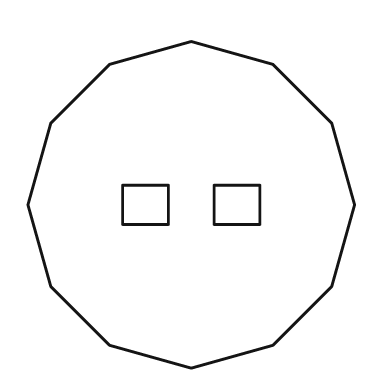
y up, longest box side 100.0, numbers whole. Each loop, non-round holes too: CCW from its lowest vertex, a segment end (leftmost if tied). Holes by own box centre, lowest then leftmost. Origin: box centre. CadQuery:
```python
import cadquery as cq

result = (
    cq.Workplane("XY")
    .moveTo(0.0, -50.0)
    .lineTo(25.0, -43.0)
    .lineTo(43.0, -25.0)
    .lineTo(50.0, 0.0)
    .lineTo(43.0, 25.0)
    .lineTo(25.0, 43.0)
    .lineTo(0.0, 50.0)
    .lineTo(-25.0, 43.0)
    .lineTo(-43.0, 25.0)
    .lineTo(-50.0, 0.0)
    .lineTo(-43.0, -25.0)
    .lineTo(-25.0, -43.0)
    .close()
    .moveTo(-21.0, -6.0)
    .lineTo(-7.0, -6.0)
    .lineTo(-7.0, 6.0)
    .lineTo(-21.0, 6.0)
    .close()
    .moveTo(7.0, -6.0)
    .lineTo(21.0, -6.0)
    .lineTo(21.0, 6.0)
    .lineTo(7.0, 6.0)
    .close()
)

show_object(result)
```